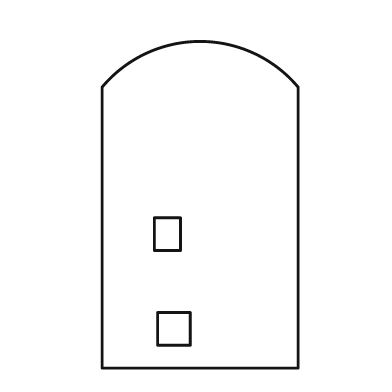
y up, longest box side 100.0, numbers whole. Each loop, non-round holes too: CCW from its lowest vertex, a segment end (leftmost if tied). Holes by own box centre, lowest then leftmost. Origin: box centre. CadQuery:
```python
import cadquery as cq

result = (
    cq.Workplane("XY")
    .moveTo(-30.0, -50.0)
    .lineTo(30.0, -50.0)
    .lineTo(30.0, 36.0)
    .threePointArc((0.0, 50.0), (-30.0, 36.0))
    .close()
    .moveTo(-13.0, -43.0)
    .lineTo(-3.0, -43.0)
    .lineTo(-3.0, -33.0)
    .lineTo(-13.0, -33.0)
    .close()
    .moveTo(-14.0, -14.0)
    .lineTo(-6.0, -14.0)
    .lineTo(-6.0, -4.0)
    .lineTo(-14.0, -4.0)
    .close()
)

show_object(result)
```